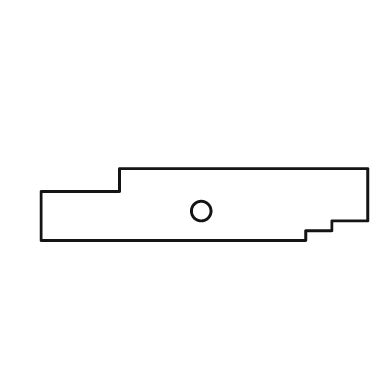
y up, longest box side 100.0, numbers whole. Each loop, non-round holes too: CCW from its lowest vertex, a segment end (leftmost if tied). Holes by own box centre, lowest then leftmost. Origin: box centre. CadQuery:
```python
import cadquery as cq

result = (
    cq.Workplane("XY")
    .moveTo(-50.0, -11.0)
    .lineTo(31.0, -11.0)
    .lineTo(31.0, -8.0)
    .lineTo(39.0, -8.0)
    .lineTo(39.0, -5.0)
    .lineTo(50.0, -5.0)
    .lineTo(50.0, 11.0)
    .lineTo(-26.0, 11.0)
    .lineTo(-26.0, 4.0)
    .lineTo(-50.0, 4.0)
    .close()
    .moveTo(-1.0, -2.0)
    .circle(3.0)
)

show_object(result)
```